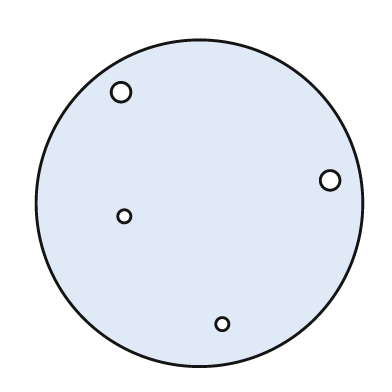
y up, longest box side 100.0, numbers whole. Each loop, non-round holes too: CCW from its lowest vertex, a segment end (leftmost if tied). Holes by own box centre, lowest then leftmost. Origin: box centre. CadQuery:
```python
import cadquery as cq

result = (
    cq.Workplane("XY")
    .moveTo(0.0, 0.0)
    .circle(50.0)
    .moveTo(7.0, -37.0)
    .circle(2.0)
    .moveTo(-23.0, -4.0)
    .circle(2.0)
    .moveTo(40.0, 7.0)
    .circle(3.0)
    .moveTo(-24.0, 34.0)
    .circle(3.0)
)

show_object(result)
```